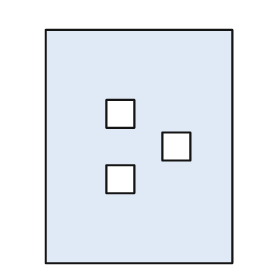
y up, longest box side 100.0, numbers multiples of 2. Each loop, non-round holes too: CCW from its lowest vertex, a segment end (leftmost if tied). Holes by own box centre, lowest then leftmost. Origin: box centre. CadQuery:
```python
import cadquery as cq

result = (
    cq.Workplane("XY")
    .moveTo(-40.0, -50.0)
    .lineTo(40.0, -50.0)
    .lineTo(40.0, 50.0)
    .lineTo(-40.0, 50.0)
    .close()
    .moveTo(-14.0, -20.0)
    .lineTo(-2.0, -20.0)
    .lineTo(-2.0, -8.0)
    .lineTo(-14.0, -8.0)
    .close()
    .moveTo(10.0, -6.0)
    .lineTo(22.0, -6.0)
    .lineTo(22.0, 6.0)
    .lineTo(10.0, 6.0)
    .close()
    .moveTo(-14.0, 8.0)
    .lineTo(-2.0, 8.0)
    .lineTo(-2.0, 20.0)
    .lineTo(-14.0, 20.0)
    .close()
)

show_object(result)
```